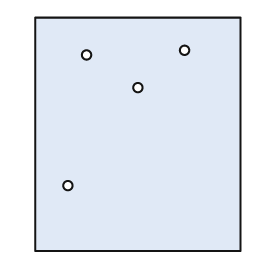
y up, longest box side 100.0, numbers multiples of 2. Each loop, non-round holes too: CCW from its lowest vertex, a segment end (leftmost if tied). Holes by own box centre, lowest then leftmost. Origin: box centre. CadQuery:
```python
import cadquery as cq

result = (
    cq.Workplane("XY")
    .moveTo(-44.0, -50.0)
    .lineTo(44.0, -50.0)
    .lineTo(44.0, 50.0)
    .lineTo(-44.0, 50.0)
    .close()
    .moveTo(-30.0, -22.0)
    .circle(2.0)
    .moveTo(0.0, 20.0)
    .circle(2.0)
    .moveTo(-22.0, 34.0)
    .circle(2.0)
    .moveTo(20.0, 36.0)
    .circle(2.0)
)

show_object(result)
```